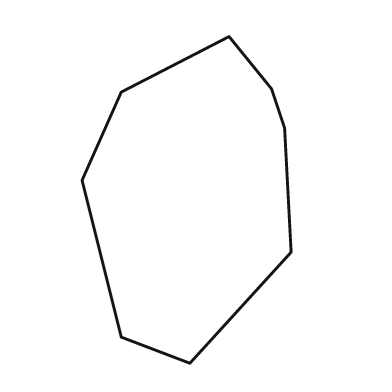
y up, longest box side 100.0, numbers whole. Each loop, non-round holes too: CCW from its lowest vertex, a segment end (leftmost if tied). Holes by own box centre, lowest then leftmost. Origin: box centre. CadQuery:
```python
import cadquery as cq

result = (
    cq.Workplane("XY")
    .moveTo(1.0, -50.0)
    .lineTo(32.0, -16.0)
    .lineTo(30.0, 22.0)
    .lineTo(26.0, 34.0)
    .lineTo(13.0, 50.0)
    .lineTo(-20.0, 33.0)
    .lineTo(-32.0, 6.0)
    .lineTo(-20.0, -42.0)
    .close()
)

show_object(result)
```